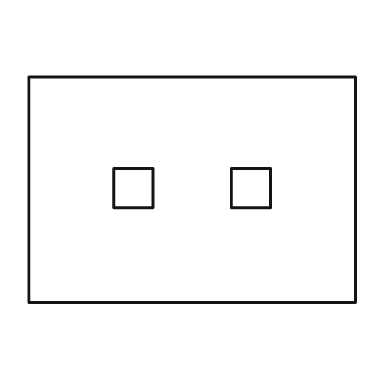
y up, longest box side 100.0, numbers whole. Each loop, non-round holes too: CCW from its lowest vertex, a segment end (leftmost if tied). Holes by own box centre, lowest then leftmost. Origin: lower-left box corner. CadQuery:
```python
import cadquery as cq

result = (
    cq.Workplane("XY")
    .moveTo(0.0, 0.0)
    .lineTo(100.0, 0.0)
    .lineTo(100.0, 69.0)
    .lineTo(0.0, 69.0)
    .close()
    .moveTo(26.0, 29.0)
    .lineTo(38.0, 29.0)
    .lineTo(38.0, 41.0)
    .lineTo(26.0, 41.0)
    .close()
    .moveTo(62.0, 29.0)
    .lineTo(74.0, 29.0)
    .lineTo(74.0, 41.0)
    .lineTo(62.0, 41.0)
    .close()
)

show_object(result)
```